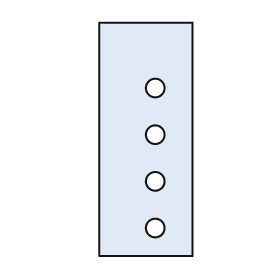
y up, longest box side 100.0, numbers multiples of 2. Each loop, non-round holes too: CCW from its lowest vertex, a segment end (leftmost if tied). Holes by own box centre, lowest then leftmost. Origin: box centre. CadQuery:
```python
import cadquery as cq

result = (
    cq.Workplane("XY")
    .moveTo(-20.0, -50.0)
    .lineTo(20.0, -50.0)
    .lineTo(20.0, 50.0)
    .lineTo(-20.0, 50.0)
    .close()
    .moveTo(4.0, -38.0)
    .circle(4.0)
    .moveTo(4.0, -18.0)
    .circle(4.0)
    .moveTo(4.0, 2.0)
    .circle(4.0)
    .moveTo(4.0, 22.0)
    .circle(4.0)
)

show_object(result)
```